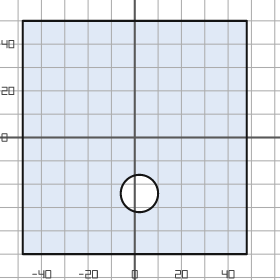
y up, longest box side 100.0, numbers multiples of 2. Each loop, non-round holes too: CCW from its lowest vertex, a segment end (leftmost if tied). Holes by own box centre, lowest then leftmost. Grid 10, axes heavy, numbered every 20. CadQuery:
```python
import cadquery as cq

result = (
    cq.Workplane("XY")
    .moveTo(-48.0, -50.0)
    .lineTo(48.0, -50.0)
    .lineTo(48.0, 50.0)
    .lineTo(-48.0, 50.0)
    .close()
    .moveTo(2.0, -24.0)
    .circle(8.0)
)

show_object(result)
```